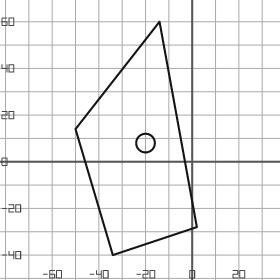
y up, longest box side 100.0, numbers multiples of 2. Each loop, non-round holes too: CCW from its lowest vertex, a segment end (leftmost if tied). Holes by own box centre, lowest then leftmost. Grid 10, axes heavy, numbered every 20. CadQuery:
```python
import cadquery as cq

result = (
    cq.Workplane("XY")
    .moveTo(-34.0, -40.0)
    .lineTo(2.0, -28.0)
    .lineTo(-14.0, 60.0)
    .lineTo(-50.0, 14.0)
    .close()
    .moveTo(-20.0, 8.0)
    .circle(4.0)
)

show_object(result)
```